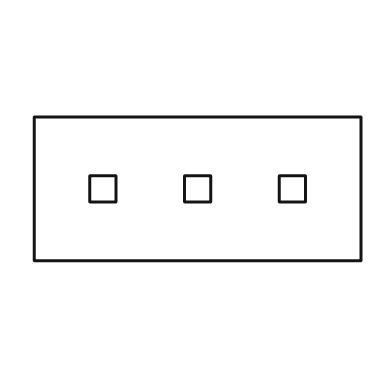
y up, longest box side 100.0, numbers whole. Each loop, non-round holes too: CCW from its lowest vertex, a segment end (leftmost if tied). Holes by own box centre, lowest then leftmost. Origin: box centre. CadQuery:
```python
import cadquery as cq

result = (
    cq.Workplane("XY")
    .moveTo(-50.0, -22.0)
    .lineTo(50.0, -22.0)
    .lineTo(50.0, 22.0)
    .lineTo(-50.0, 22.0)
    .close()
    .moveTo(-33.0, -4.0)
    .lineTo(-25.0, -4.0)
    .lineTo(-25.0, 4.0)
    .lineTo(-33.0, 4.0)
    .close()
    .moveTo(-4.0, -4.0)
    .lineTo(4.0, -4.0)
    .lineTo(4.0, 4.0)
    .lineTo(-4.0, 4.0)
    .close()
    .moveTo(25.0, -4.0)
    .lineTo(33.0, -4.0)
    .lineTo(33.0, 4.0)
    .lineTo(25.0, 4.0)
    .close()
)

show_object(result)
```